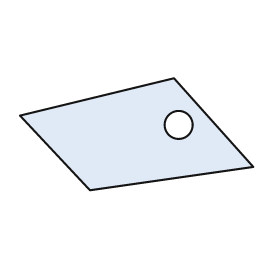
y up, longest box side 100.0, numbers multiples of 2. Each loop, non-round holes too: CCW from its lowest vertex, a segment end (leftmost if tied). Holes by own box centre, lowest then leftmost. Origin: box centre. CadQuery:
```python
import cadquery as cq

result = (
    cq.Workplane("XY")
    .moveTo(-20.0, -24.0)
    .lineTo(50.0, -14.0)
    .lineTo(16.0, 24.0)
    .lineTo(-50.0, 8.0)
    .close()
    .moveTo(18.0, 4.0)
    .circle(6.0)
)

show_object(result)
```